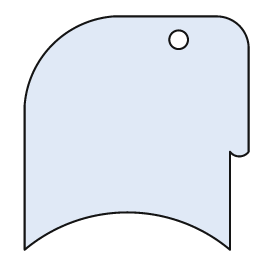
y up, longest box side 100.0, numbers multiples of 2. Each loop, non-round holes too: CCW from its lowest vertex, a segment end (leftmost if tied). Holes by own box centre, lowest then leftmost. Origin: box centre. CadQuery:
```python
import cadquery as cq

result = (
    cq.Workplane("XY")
    .moveTo(-48.0, -50.0)
    .threePointArc((-4.0, -34.0), (40.0, -50.0))
    .lineTo(40.0, -8.0)
    .threePointArc((44.0, -10.0), (48.0, -8.0))
    .lineTo(48.0, 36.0)
    .threePointArc((44.0, 46.0), (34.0, 50.0))
    .lineTo(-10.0, 50.0)
    .threePointArc((-36.0, 38.0), (-48.0, 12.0))
    .close()
    .moveTo(18.0, 40.0)
    .circle(4.0)
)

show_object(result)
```